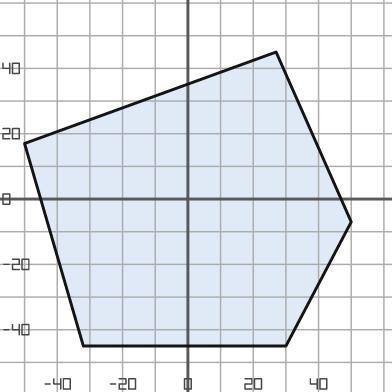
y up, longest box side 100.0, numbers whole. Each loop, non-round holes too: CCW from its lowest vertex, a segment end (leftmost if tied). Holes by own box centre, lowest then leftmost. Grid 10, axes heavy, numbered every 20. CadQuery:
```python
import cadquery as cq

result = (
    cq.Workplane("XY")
    .moveTo(-32.0, -45.0)
    .lineTo(30.0, -45.0)
    .lineTo(50.0, -7.0)
    .lineTo(27.0, 45.0)
    .lineTo(-50.0, 17.0)
    .close()
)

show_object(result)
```